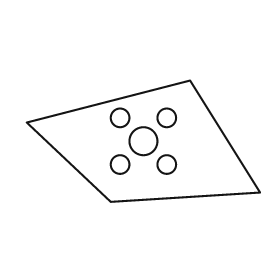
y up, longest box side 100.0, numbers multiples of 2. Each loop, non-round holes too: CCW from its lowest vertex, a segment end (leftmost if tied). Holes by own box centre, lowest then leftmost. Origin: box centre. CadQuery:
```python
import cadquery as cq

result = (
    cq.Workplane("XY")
    .moveTo(-14.0, -26.0)
    .lineTo(50.0, -22.0)
    .lineTo(20.0, 26.0)
    .lineTo(-50.0, 8.0)
    .close()
    .moveTo(-10.0, -10.0)
    .circle(4.0)
    .moveTo(10.0, -10.0)
    .circle(4.0)
    .moveTo(0.0, 0.0)
    .circle(6.0)
    .moveTo(-10.0, 10.0)
    .circle(4.0)
    .moveTo(10.0, 10.0)
    .circle(4.0)
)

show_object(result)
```